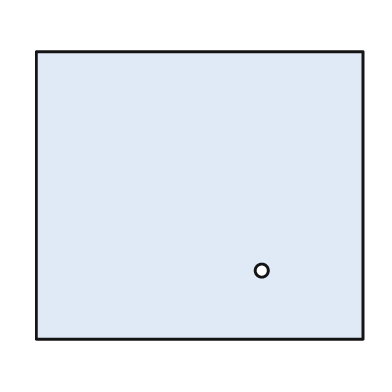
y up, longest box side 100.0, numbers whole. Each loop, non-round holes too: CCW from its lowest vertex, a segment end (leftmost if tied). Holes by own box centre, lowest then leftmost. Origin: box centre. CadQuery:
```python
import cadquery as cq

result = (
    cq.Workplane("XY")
    .moveTo(-50.0, -44.0)
    .lineTo(50.0, -44.0)
    .lineTo(50.0, 44.0)
    .lineTo(-50.0, 44.0)
    .close()
    .moveTo(19.0, -23.0)
    .circle(2.0)
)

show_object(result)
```